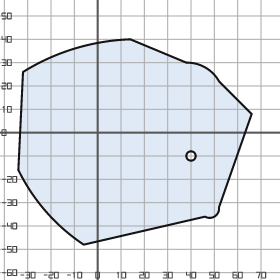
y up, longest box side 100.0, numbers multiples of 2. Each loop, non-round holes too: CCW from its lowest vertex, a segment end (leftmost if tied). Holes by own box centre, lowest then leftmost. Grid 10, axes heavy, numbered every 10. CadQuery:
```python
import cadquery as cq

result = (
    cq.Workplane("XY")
    .moveTo(-6.0, -48.0)
    .lineTo(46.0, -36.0)
    .threePointArc((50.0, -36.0), (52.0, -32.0))
    .lineTo(66.0, 8.0)
    .lineTo(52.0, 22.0)
    .threePointArc((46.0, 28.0), (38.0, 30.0))
    .lineTo(14.0, 40.0)
    .threePointArc((-10.0, 36.0), (-32.0, 26.0))
    .lineTo(-34.0, -16.0)
    .threePointArc((-22.0, -34.0), (-6.0, -48.0))
    .close()
    .moveTo(40.0, -10.0)
    .circle(2.0)
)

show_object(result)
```